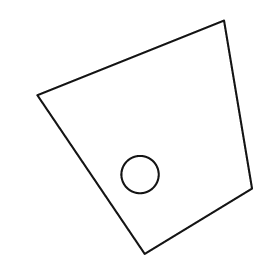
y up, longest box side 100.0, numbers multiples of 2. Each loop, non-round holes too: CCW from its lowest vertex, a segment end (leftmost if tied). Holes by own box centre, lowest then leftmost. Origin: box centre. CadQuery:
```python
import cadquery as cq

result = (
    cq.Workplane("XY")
    .moveTo(0.0, -50.0)
    .lineTo(46.0, -22.0)
    .lineTo(34.0, 50.0)
    .lineTo(-46.0, 18.0)
    .close()
    .moveTo(-2.0, -16.0)
    .circle(8.0)
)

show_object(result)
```